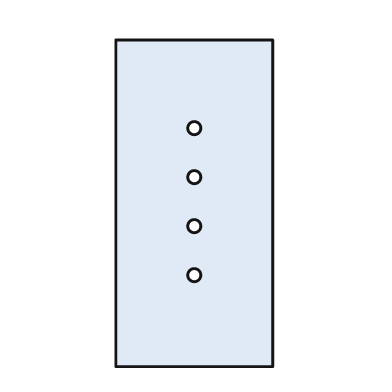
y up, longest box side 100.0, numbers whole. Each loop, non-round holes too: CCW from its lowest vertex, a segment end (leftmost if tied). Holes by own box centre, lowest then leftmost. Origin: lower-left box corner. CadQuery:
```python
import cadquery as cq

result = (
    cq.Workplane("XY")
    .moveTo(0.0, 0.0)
    .lineTo(48.0, 0.0)
    .lineTo(48.0, 100.0)
    .lineTo(0.0, 100.0)
    .close()
    .moveTo(24.0, 28.0)
    .circle(2.0)
    .moveTo(24.0, 43.0)
    .circle(2.0)
    .moveTo(24.0, 58.0)
    .circle(2.0)
    .moveTo(24.0, 73.0)
    .circle(2.0)
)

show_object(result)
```